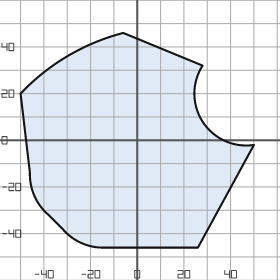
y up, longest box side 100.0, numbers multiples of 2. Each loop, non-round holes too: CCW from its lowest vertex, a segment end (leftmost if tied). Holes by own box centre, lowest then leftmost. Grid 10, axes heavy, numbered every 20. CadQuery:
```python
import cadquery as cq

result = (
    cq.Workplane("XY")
    .moveTo(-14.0, -46.0)
    .lineTo(26.0, -46.0)
    .lineTo(50.0, -2.0)
    .threePointArc((28.0, 8.0), (28.0, 32.0))
    .lineTo(-6.0, 46.0)
    .threePointArc((-30.0, 36.0), (-50.0, 20.0))
    .lineTo(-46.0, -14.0)
    .threePointArc((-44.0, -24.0), (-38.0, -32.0))
    .lineTo(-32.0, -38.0)
    .threePointArc((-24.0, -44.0), (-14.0, -46.0))
    .close()
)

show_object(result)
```